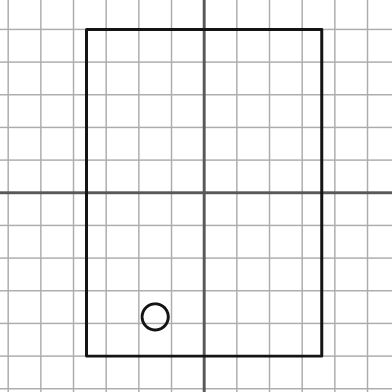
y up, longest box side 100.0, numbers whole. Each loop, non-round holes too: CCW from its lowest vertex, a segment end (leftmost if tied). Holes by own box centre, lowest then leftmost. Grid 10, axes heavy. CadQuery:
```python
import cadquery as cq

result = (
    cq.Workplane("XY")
    .moveTo(-36.0, -50.0)
    .lineTo(36.0, -50.0)
    .lineTo(36.0, 50.0)
    .lineTo(-36.0, 50.0)
    .close()
    .moveTo(-15.0, -38.0)
    .circle(4.0)
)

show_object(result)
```